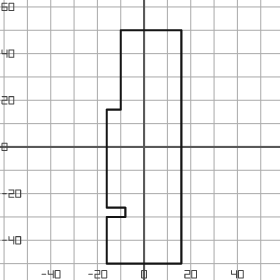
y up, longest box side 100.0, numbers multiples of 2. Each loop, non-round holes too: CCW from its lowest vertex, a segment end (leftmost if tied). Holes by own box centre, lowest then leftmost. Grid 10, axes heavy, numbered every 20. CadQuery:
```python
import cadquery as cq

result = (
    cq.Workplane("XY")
    .moveTo(-16.0, -50.0)
    .lineTo(16.0, -50.0)
    .lineTo(16.0, 50.0)
    .lineTo(-10.0, 50.0)
    .lineTo(-10.0, 16.0)
    .lineTo(-16.0, 16.0)
    .lineTo(-16.0, -26.0)
    .lineTo(-8.0, -26.0)
    .lineTo(-8.0, -30.0)
    .lineTo(-16.0, -30.0)
    .close()
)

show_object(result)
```